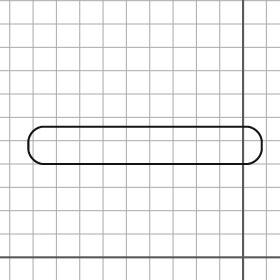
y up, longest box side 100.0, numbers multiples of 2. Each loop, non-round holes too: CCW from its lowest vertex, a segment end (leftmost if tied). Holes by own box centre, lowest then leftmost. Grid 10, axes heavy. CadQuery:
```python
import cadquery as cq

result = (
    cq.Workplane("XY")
    .moveTo(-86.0, 40.0)
    .lineTo(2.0, 40.0)
    .threePointArc((6.0, 42.0), (8.0, 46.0))
    .lineTo(8.0, 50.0)
    .threePointArc((6.0, 54.0), (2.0, 56.0))
    .lineTo(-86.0, 56.0)
    .threePointArc((-90.0, 54.0), (-92.0, 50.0))
    .lineTo(-92.0, 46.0)
    .threePointArc((-90.0, 42.0), (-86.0, 40.0))
    .close()
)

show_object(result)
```